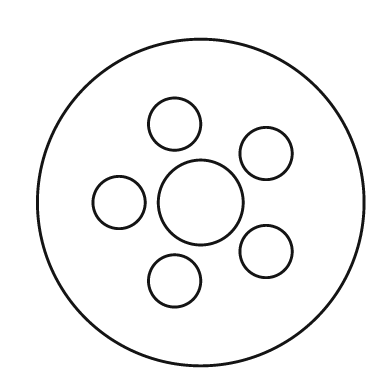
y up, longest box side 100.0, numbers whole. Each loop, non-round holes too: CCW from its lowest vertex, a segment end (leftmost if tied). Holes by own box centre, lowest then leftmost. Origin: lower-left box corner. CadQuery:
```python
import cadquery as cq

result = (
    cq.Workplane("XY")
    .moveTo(50.0, 50.0)
    .circle(50.0)
    .moveTo(42.0, 26.0)
    .circle(8.0)
    .moveTo(70.0, 35.0)
    .circle(8.0)
    .moveTo(25.0, 50.0)
    .circle(8.0)
    .moveTo(50.0, 50.0)
    .circle(13.0)
    .moveTo(70.0, 65.0)
    .circle(8.0)
    .moveTo(42.0, 74.0)
    .circle(8.0)
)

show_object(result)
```